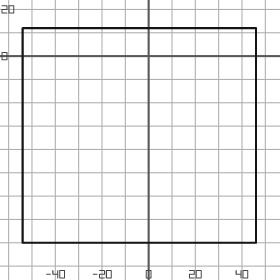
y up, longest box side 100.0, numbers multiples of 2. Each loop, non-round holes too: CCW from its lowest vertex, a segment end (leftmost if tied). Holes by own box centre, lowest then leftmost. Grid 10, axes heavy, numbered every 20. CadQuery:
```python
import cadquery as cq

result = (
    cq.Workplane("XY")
    .moveTo(-54.0, -80.0)
    .lineTo(46.0, -80.0)
    .lineTo(46.0, 12.0)
    .lineTo(-54.0, 12.0)
    .close()
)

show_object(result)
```